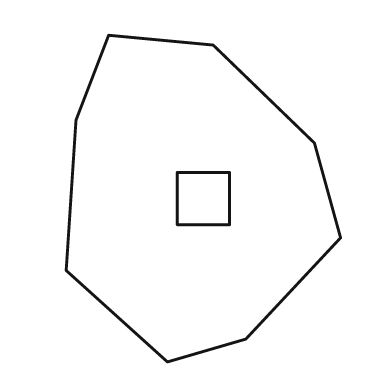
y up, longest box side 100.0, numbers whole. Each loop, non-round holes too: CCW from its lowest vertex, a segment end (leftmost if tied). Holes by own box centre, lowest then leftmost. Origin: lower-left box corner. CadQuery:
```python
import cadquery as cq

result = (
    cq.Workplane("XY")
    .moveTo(31.0, 0.0)
    .lineTo(55.0, 7.0)
    .lineTo(84.0, 38.0)
    .lineTo(76.0, 67.0)
    .lineTo(45.0, 97.0)
    .lineTo(13.0, 100.0)
    .lineTo(3.0, 74.0)
    .lineTo(0.0, 28.0)
    .close()
    .moveTo(34.0, 42.0)
    .lineTo(50.0, 42.0)
    .lineTo(50.0, 58.0)
    .lineTo(34.0, 58.0)
    .close()
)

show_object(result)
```